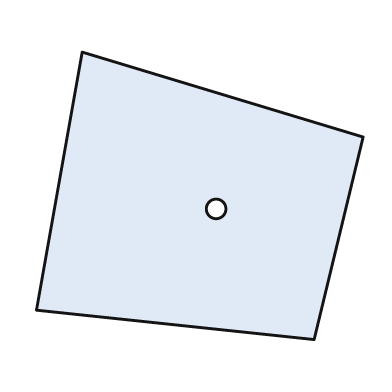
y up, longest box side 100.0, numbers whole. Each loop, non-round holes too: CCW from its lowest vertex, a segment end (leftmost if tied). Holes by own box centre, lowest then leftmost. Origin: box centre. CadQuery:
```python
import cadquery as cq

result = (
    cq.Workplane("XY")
    .moveTo(35.0, -44.0)
    .lineTo(50.0, 18.0)
    .lineTo(-36.0, 44.0)
    .lineTo(-50.0, -35.0)
    .close()
    .moveTo(5.0, -4.0)
    .circle(3.0)
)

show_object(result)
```